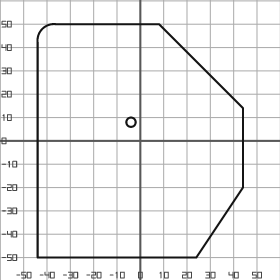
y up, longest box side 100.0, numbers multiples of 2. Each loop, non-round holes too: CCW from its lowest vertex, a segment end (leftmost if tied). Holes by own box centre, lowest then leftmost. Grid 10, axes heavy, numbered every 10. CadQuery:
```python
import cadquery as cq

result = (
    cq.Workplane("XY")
    .moveTo(-44.0, -50.0)
    .lineTo(24.0, -50.0)
    .lineTo(44.0, -20.0)
    .lineTo(44.0, 14.0)
    .lineTo(8.0, 50.0)
    .lineTo(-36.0, 50.0)
    .threePointArc((-42.0, 48.0), (-44.0, 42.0))
    .close()
    .moveTo(-4.0, 8.0)
    .circle(2.0)
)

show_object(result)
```